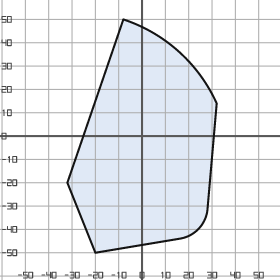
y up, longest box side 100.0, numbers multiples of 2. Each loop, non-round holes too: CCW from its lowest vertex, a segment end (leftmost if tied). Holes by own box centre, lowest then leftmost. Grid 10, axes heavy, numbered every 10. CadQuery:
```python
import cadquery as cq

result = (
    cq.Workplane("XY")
    .moveTo(-20.0, -50.0)
    .lineTo(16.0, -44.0)
    .threePointArc((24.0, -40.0), (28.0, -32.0))
    .lineTo(32.0, 14.0)
    .threePointArc((16.0, 36.0), (-8.0, 50.0))
    .lineTo(-32.0, -20.0)
    .close()
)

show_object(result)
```